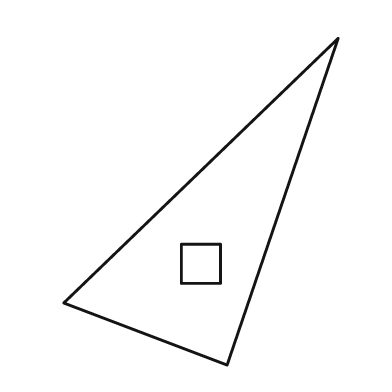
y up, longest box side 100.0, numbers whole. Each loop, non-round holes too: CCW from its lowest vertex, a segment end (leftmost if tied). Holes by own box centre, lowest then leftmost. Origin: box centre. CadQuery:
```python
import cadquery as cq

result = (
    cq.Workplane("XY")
    .moveTo(8.0, -50.0)
    .lineTo(42.0, 50.0)
    .lineTo(-42.0, -31.0)
    .close()
    .moveTo(-6.0, -25.0)
    .lineTo(6.0, -25.0)
    .lineTo(6.0, -13.0)
    .lineTo(-6.0, -13.0)
    .close()
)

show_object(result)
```